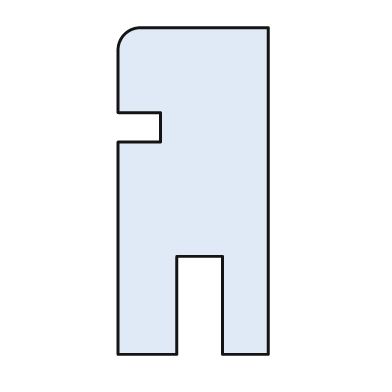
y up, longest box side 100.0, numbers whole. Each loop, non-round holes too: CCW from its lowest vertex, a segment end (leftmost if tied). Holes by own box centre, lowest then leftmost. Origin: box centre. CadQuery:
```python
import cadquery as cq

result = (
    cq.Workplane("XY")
    .moveTo(-23.0, -50.0)
    .lineTo(-5.0, -50.0)
    .lineTo(-5.0, -20.0)
    .lineTo(9.0, -20.0)
    .lineTo(9.0, -50.0)
    .lineTo(23.0, -50.0)
    .lineTo(23.0, 50.0)
    .lineTo(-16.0, 50.0)
    .threePointArc((-21.0, 48.0), (-23.0, 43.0))
    .lineTo(-23.0, 24.0)
    .lineTo(-10.0, 24.0)
    .lineTo(-10.0, 15.0)
    .lineTo(-23.0, 15.0)
    .close()
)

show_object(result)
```